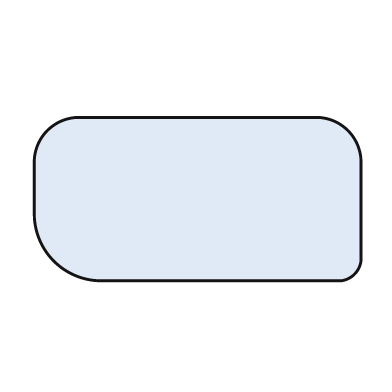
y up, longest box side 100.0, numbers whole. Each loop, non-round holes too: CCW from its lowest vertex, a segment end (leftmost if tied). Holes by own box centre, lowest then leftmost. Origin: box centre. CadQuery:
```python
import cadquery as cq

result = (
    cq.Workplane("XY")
    .moveTo(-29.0, -25.0)
    .lineTo(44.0, -25.0)
    .threePointArc((48.0, -23.0), (50.0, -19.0))
    .lineTo(50.0, 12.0)
    .threePointArc((46.0, 21.0), (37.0, 25.0))
    .lineTo(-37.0, 25.0)
    .threePointArc((-46.0, 21.0), (-50.0, 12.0))
    .lineTo(-50.0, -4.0)
    .threePointArc((-44.0, -19.0), (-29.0, -25.0))
    .close()
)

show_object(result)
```